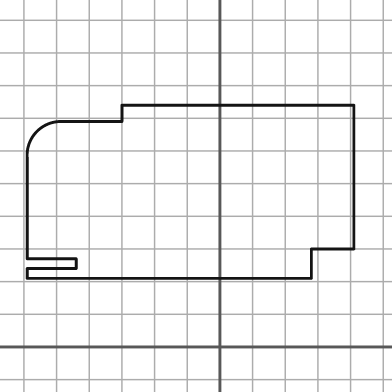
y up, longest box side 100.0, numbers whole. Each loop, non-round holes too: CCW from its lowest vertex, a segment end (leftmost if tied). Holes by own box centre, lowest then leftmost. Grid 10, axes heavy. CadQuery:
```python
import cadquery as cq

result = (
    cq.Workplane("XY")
    .moveTo(-59.0, 21.0)
    .lineTo(28.0, 21.0)
    .lineTo(28.0, 30.0)
    .lineTo(41.0, 30.0)
    .lineTo(41.0, 74.0)
    .lineTo(-30.0, 74.0)
    .lineTo(-30.0, 69.0)
    .lineTo(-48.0, 69.0)
    .threePointArc((-56.0, 66.0), (-59.0, 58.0))
    .lineTo(-59.0, 27.0)
    .lineTo(-44.0, 27.0)
    .lineTo(-44.0, 24.0)
    .lineTo(-59.0, 24.0)
    .close()
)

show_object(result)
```